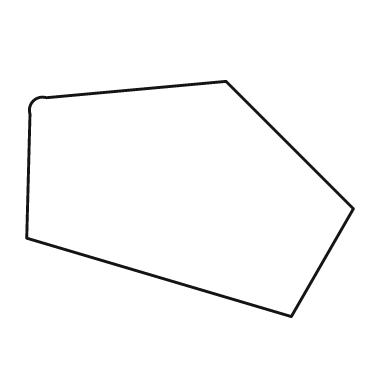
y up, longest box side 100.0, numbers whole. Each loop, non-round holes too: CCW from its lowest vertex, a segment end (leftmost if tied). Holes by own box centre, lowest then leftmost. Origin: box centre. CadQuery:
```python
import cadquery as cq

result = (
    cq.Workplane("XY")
    .moveTo(31.0, -36.0)
    .lineTo(50.0, -3.0)
    .lineTo(11.0, 36.0)
    .lineTo(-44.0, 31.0)
    .threePointArc((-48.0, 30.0), (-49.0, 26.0))
    .lineTo(-50.0, -12.0)
    .close()
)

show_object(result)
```